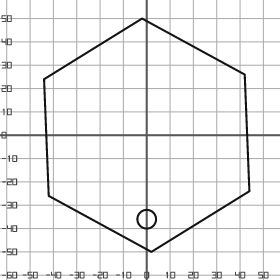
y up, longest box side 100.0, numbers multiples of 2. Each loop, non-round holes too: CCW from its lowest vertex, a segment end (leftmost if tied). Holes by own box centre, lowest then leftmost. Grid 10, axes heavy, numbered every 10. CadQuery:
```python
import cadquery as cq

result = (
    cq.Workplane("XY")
    .moveTo(2.0, -50.0)
    .lineTo(44.0, -24.0)
    .lineTo(42.0, 26.0)
    .lineTo(-2.0, 50.0)
    .lineTo(-44.0, 24.0)
    .lineTo(-42.0, -26.0)
    .close()
    .moveTo(0.0, -36.0)
    .circle(4.0)
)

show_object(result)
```